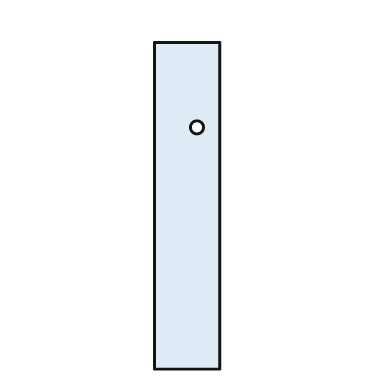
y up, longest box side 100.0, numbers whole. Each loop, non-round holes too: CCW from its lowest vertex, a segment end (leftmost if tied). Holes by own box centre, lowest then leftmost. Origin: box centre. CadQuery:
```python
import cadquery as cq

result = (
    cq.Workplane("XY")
    .moveTo(-10.0, -50.0)
    .lineTo(10.0, -50.0)
    .lineTo(10.0, 50.0)
    .lineTo(-10.0, 50.0)
    .close()
    .moveTo(3.0, 24.0)
    .circle(2.0)
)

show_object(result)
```